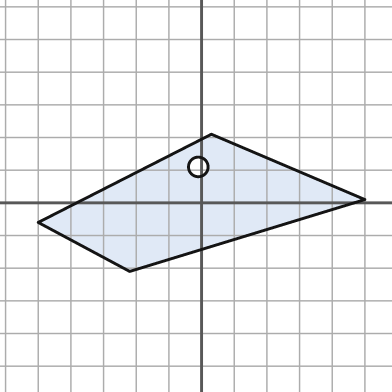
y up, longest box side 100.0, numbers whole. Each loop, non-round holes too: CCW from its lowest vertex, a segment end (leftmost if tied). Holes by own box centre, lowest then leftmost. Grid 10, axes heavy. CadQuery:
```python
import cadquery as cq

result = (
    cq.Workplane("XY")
    .moveTo(-22.0, -21.0)
    .lineTo(50.0, 1.0)
    .lineTo(3.0, 21.0)
    .lineTo(-50.0, -6.0)
    .close()
    .moveTo(-1.0, 11.0)
    .circle(3.0)
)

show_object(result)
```